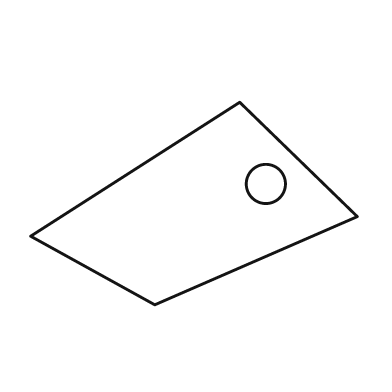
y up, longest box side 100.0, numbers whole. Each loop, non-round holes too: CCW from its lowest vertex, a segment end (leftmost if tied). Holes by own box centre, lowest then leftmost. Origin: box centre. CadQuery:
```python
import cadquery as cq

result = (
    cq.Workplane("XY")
    .moveTo(-12.0, -31.0)
    .lineTo(50.0, -4.0)
    .lineTo(14.0, 31.0)
    .lineTo(-50.0, -10.0)
    .close()
    .moveTo(22.0, 6.0)
    .circle(6.0)
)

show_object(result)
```